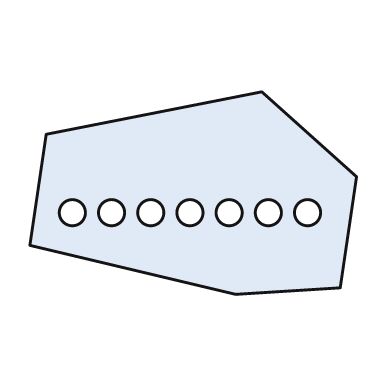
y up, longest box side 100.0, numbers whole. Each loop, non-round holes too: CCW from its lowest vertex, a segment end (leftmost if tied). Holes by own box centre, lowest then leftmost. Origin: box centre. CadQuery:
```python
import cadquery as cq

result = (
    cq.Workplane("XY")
    .moveTo(13.0, -31.0)
    .lineTo(45.0, -29.0)
    .lineTo(50.0, 5.0)
    .lineTo(21.0, 31.0)
    .lineTo(-45.0, 18.0)
    .lineTo(-50.0, -16.0)
    .close()
    .moveTo(-37.0, -6.0)
    .circle(4.0)
    .moveTo(-25.0, -6.0)
    .circle(4.0)
    .moveTo(-13.0, -6.0)
    .circle(4.0)
    .moveTo(-1.0, -6.0)
    .circle(4.0)
    .moveTo(11.0, -6.0)
    .circle(4.0)
    .moveTo(23.0, -6.0)
    .circle(4.0)
    .moveTo(35.0, -6.0)
    .circle(4.0)
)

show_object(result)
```